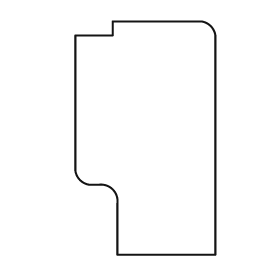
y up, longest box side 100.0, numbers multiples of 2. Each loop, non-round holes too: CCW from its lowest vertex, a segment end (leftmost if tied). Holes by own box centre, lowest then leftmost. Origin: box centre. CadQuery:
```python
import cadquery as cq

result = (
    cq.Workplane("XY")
    .moveTo(-12.0, -50.0)
    .lineTo(30.0, -50.0)
    .lineTo(30.0, 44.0)
    .threePointArc((28.0, 48.0), (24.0, 50.0))
    .lineTo(-14.0, 50.0)
    .lineTo(-14.0, 44.0)
    .lineTo(-30.0, 44.0)
    .lineTo(-30.0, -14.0)
    .threePointArc((-28.0, -18.0), (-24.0, -20.0))
    .lineTo(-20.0, -20.0)
    .threePointArc((-14.0, -22.0), (-12.0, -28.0))
    .close()
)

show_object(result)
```